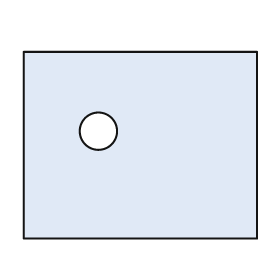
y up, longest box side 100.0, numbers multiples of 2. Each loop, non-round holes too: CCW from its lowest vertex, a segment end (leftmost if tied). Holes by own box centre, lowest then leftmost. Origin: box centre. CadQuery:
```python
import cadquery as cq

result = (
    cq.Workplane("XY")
    .moveTo(-50.0, -40.0)
    .lineTo(50.0, -40.0)
    .lineTo(50.0, 40.0)
    .lineTo(-50.0, 40.0)
    .close()
    .moveTo(-18.0, 6.0)
    .circle(8.0)
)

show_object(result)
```